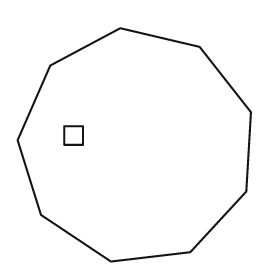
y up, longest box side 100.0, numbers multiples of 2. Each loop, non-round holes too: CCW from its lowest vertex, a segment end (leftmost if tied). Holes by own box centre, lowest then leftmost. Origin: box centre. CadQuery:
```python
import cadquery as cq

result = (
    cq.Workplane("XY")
    .moveTo(-10.0, -50.0)
    .lineTo(24.0, -46.0)
    .lineTo(48.0, -20.0)
    .lineTo(50.0, 14.0)
    .lineTo(28.0, 42.0)
    .lineTo(-6.0, 50.0)
    .lineTo(-36.0, 34.0)
    .lineTo(-50.0, 2.0)
    .lineTo(-40.0, -30.0)
    .close()
    .moveTo(-30.0, 0.0)
    .lineTo(-22.0, 0.0)
    .lineTo(-22.0, 8.0)
    .lineTo(-30.0, 8.0)
    .close()
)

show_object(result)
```